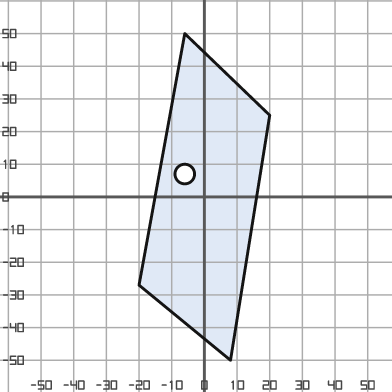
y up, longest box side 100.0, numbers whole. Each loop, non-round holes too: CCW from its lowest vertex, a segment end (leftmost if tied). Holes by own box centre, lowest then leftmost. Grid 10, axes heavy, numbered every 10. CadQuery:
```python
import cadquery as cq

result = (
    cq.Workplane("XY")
    .moveTo(8.0, -50.0)
    .lineTo(20.0, 25.0)
    .lineTo(-6.0, 50.0)
    .lineTo(-20.0, -27.0)
    .close()
    .moveTo(-6.0, 7.0)
    .circle(3.0)
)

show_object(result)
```